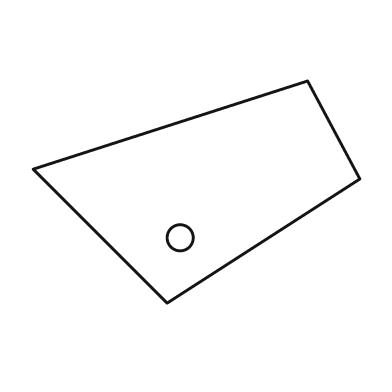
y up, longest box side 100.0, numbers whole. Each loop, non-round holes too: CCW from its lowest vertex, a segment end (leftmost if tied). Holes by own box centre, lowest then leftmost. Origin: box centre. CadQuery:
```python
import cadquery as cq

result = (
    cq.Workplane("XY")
    .moveTo(-9.0, -34.0)
    .lineTo(50.0, 4.0)
    .lineTo(34.0, 34.0)
    .lineTo(-50.0, 7.0)
    .close()
    .moveTo(-5.0, -14.0)
    .circle(4.0)
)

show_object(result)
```